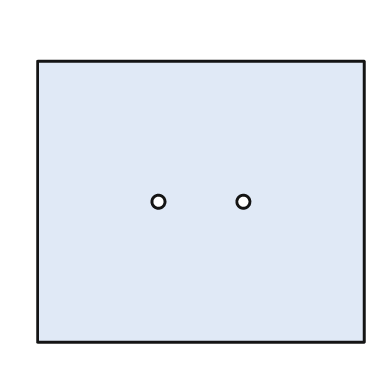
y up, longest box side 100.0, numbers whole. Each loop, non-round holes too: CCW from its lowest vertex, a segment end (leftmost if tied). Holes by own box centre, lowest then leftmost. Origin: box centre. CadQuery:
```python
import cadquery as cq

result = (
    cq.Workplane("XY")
    .moveTo(-50.0, -43.0)
    .lineTo(50.0, -43.0)
    .lineTo(50.0, 43.0)
    .lineTo(-50.0, 43.0)
    .close()
    .moveTo(-13.0, 0.0)
    .circle(2.0)
    .moveTo(13.0, 0.0)
    .circle(2.0)
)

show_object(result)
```